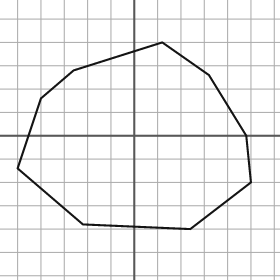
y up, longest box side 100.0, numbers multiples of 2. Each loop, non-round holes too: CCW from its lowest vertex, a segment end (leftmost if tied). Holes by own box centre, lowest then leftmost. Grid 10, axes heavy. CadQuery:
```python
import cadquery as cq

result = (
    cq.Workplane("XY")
    .moveTo(24.0, -40.0)
    .lineTo(50.0, -20.0)
    .lineTo(48.0, 0.0)
    .lineTo(32.0, 26.0)
    .lineTo(12.0, 40.0)
    .lineTo(-26.0, 28.0)
    .lineTo(-40.0, 16.0)
    .lineTo(-50.0, -14.0)
    .lineTo(-22.0, -38.0)
    .close()
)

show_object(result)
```